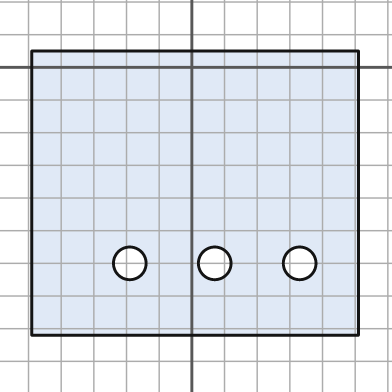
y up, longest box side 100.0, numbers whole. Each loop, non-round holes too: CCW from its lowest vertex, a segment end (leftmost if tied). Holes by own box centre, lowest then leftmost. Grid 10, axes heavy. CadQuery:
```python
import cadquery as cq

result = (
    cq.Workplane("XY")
    .moveTo(-49.0, -82.0)
    .lineTo(51.0, -82.0)
    .lineTo(51.0, 5.0)
    .lineTo(-49.0, 5.0)
    .close()
    .moveTo(-19.0, -60.0)
    .circle(5.0)
    .moveTo(7.0, -60.0)
    .circle(5.0)
    .moveTo(33.0, -60.0)
    .circle(5.0)
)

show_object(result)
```